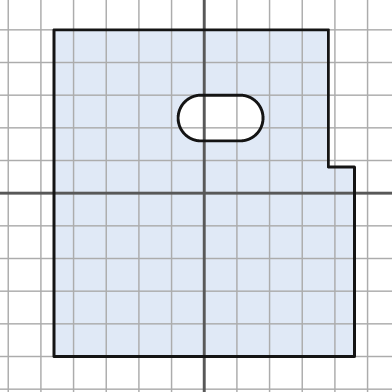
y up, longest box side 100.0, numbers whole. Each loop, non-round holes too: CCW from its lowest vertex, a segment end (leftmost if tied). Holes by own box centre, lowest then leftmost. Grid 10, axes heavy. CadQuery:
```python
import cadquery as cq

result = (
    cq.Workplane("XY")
    .moveTo(-46.0, -50.0)
    .lineTo(46.0, -50.0)
    .lineTo(46.0, 8.0)
    .lineTo(38.0, 8.0)
    .lineTo(38.0, 50.0)
    .lineTo(-46.0, 50.0)
    .close()
    .moveTo(-1.0, 16.0)
    .lineTo(11.0, 16.0)
    .threePointArc((18.0, 23.0), (11.0, 30.0))
    .lineTo(-1.0, 30.0)
    .threePointArc((-8.0, 23.0), (-1.0, 16.0))
    .close()
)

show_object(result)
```